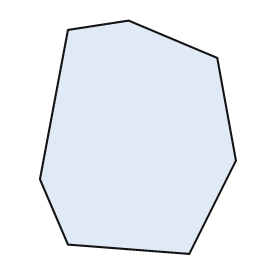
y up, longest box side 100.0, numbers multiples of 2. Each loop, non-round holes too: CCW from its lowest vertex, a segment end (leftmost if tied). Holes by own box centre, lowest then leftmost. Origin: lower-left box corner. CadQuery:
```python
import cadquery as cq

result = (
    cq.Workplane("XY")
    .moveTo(64.0, 0.0)
    .lineTo(84.0, 40.0)
    .lineTo(76.0, 84.0)
    .lineTo(38.0, 100.0)
    .lineTo(12.0, 96.0)
    .lineTo(0.0, 32.0)
    .lineTo(12.0, 4.0)
    .close()
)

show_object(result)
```